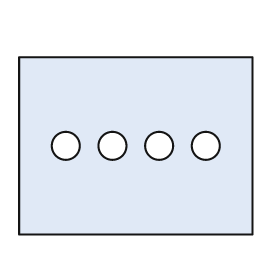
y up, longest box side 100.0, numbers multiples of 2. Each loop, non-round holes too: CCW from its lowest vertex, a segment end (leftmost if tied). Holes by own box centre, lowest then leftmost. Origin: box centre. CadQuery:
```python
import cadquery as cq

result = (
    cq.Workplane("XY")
    .moveTo(-50.0, -38.0)
    .lineTo(50.0, -38.0)
    .lineTo(50.0, 38.0)
    .lineTo(-50.0, 38.0)
    .close()
    .moveTo(-30.0, 0.0)
    .circle(6.0)
    .moveTo(-10.0, 0.0)
    .circle(6.0)
    .moveTo(10.0, 0.0)
    .circle(6.0)
    .moveTo(30.0, 0.0)
    .circle(6.0)
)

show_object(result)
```